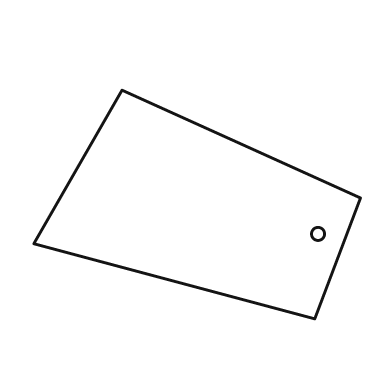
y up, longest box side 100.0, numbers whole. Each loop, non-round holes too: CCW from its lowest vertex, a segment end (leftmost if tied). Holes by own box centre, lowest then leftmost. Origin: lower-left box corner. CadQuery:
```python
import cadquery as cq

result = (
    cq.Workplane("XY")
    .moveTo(86.0, 0.0)
    .lineTo(100.0, 37.0)
    .lineTo(27.0, 70.0)
    .lineTo(0.0, 23.0)
    .close()
    .moveTo(87.0, 26.0)
    .circle(2.0)
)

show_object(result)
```